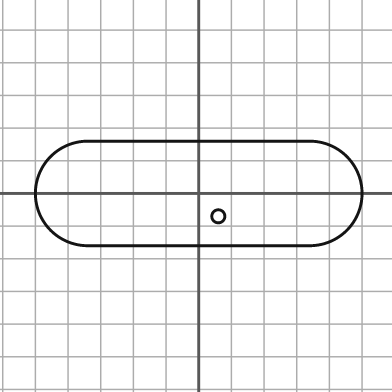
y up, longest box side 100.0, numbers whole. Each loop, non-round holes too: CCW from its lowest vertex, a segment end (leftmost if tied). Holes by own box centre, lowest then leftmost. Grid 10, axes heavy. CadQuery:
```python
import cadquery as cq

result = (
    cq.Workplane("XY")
    .moveTo(-34.0, -16.0)
    .lineTo(34.0, -16.0)
    .threePointArc((50.0, 0.0), (34.0, 16.0))
    .lineTo(-34.0, 16.0)
    .threePointArc((-50.0, 0.0), (-34.0, -16.0))
    .close()
    .moveTo(6.0, -7.0)
    .circle(2.0)
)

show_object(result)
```